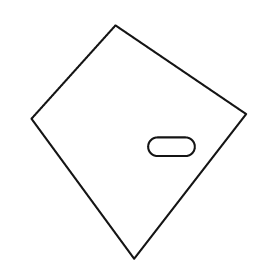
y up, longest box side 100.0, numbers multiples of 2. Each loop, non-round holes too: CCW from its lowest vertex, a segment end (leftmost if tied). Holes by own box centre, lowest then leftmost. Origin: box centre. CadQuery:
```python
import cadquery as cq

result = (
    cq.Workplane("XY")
    .moveTo(-2.0, -50.0)
    .lineTo(46.0, 12.0)
    .lineTo(-10.0, 50.0)
    .lineTo(-46.0, 10.0)
    .close()
    .moveTo(8.0, -6.0)
    .lineTo(20.0, -6.0)
    .threePointArc((24.0, -2.0), (20.0, 2.0))
    .lineTo(8.0, 2.0)
    .threePointArc((4.0, -2.0), (8.0, -6.0))
    .close()
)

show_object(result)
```